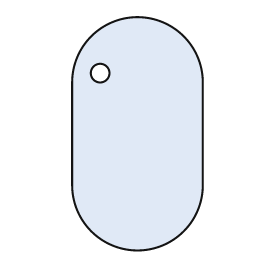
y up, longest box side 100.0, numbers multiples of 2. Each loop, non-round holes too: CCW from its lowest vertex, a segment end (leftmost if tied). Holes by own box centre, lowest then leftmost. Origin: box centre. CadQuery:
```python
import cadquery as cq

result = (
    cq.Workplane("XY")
    .moveTo(-28.0, -22.0)
    .threePointArc((0.0, -50.0), (28.0, -22.0))
    .lineTo(28.0, 22.0)
    .threePointArc((0.0, 50.0), (-28.0, 22.0))
    .close()
    .moveTo(-16.0, 26.0)
    .circle(4.0)
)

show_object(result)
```